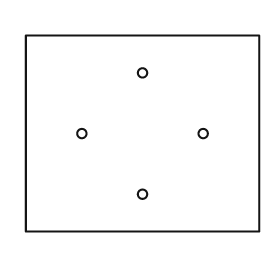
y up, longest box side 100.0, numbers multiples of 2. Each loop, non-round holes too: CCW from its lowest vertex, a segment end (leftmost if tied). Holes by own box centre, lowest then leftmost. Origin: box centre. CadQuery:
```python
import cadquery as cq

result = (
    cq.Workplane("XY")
    .moveTo(-50.0, -42.0)
    .lineTo(50.0, -42.0)
    .lineTo(50.0, 42.0)
    .lineTo(-50.0, 42.0)
    .close()
    .moveTo(0.0, -26.0)
    .circle(2.0)
    .moveTo(-26.0, 0.0)
    .circle(2.0)
    .moveTo(26.0, 0.0)
    .circle(2.0)
    .moveTo(0.0, 26.0)
    .circle(2.0)
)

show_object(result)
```